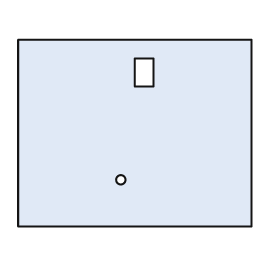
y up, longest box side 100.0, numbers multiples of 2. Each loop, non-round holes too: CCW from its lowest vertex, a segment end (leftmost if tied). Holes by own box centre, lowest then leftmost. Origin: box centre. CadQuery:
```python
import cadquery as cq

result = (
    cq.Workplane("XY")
    .moveTo(-50.0, -40.0)
    .lineTo(50.0, -40.0)
    .lineTo(50.0, 40.0)
    .lineTo(-50.0, 40.0)
    .close()
    .moveTo(-6.0, -20.0)
    .circle(2.0)
    .moveTo(0.0, 20.0)
    .lineTo(8.0, 20.0)
    .lineTo(8.0, 32.0)
    .lineTo(0.0, 32.0)
    .close()
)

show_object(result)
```